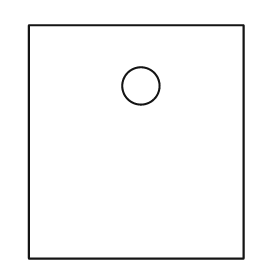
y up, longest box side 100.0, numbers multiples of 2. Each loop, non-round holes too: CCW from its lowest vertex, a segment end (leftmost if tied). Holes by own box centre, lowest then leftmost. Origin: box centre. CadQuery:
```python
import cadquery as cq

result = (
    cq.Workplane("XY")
    .moveTo(-46.0, -50.0)
    .lineTo(46.0, -50.0)
    .lineTo(46.0, 50.0)
    .lineTo(-46.0, 50.0)
    .close()
    .moveTo(2.0, 24.0)
    .circle(8.0)
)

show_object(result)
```